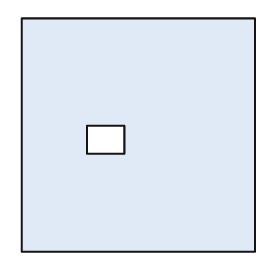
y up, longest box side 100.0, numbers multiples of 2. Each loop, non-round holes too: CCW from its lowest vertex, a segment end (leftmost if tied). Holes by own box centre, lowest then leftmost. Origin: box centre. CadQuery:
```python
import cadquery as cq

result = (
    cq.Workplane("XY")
    .moveTo(-50.0, -50.0)
    .lineTo(50.0, -50.0)
    .lineTo(50.0, 50.0)
    .lineTo(-50.0, 50.0)
    .close()
    .moveTo(-22.0, -8.0)
    .lineTo(-6.0, -8.0)
    .lineTo(-6.0, 4.0)
    .lineTo(-22.0, 4.0)
    .close()
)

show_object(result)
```